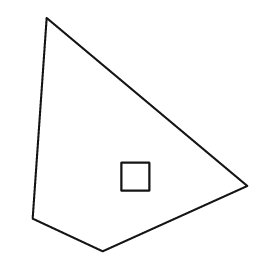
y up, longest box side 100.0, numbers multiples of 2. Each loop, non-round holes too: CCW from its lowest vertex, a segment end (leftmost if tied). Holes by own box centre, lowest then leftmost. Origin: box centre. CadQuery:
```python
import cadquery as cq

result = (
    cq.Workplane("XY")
    .moveTo(-16.0, -50.0)
    .lineTo(46.0, -22.0)
    .lineTo(-40.0, 50.0)
    .lineTo(-46.0, -36.0)
    .close()
    .moveTo(-8.0, -24.0)
    .lineTo(4.0, -24.0)
    .lineTo(4.0, -12.0)
    .lineTo(-8.0, -12.0)
    .close()
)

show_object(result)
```